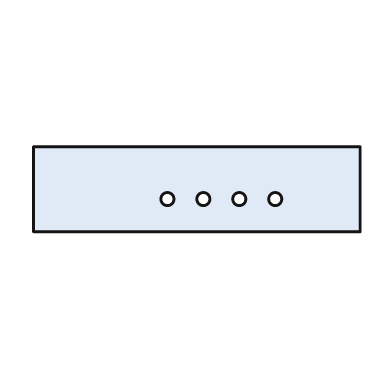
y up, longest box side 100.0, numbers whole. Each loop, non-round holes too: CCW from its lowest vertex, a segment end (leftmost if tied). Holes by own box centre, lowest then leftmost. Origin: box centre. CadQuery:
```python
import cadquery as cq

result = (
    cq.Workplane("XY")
    .moveTo(-50.0, -13.0)
    .lineTo(50.0, -13.0)
    .lineTo(50.0, 13.0)
    .lineTo(-50.0, 13.0)
    .close()
    .moveTo(-9.0, -3.0)
    .circle(2.0)
    .moveTo(2.0, -3.0)
    .circle(2.0)
    .moveTo(13.0, -3.0)
    .circle(2.0)
    .moveTo(24.0, -3.0)
    .circle(2.0)
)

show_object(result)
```